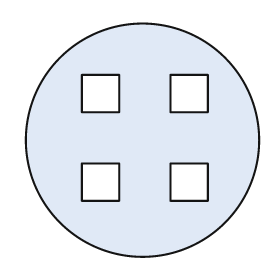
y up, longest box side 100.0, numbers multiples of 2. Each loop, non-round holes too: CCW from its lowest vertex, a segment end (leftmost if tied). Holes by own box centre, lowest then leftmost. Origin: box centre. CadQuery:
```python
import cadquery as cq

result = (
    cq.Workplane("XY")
    .moveTo(0.0, 0.0)
    .circle(50.0)
    .moveTo(-26.0, -26.0)
    .lineTo(-10.0, -26.0)
    .lineTo(-10.0, -10.0)
    .lineTo(-26.0, -10.0)
    .close()
    .moveTo(12.0, -26.0)
    .lineTo(28.0, -26.0)
    .lineTo(28.0, -10.0)
    .lineTo(12.0, -10.0)
    .close()
    .moveTo(-26.0, 12.0)
    .lineTo(-10.0, 12.0)
    .lineTo(-10.0, 28.0)
    .lineTo(-26.0, 28.0)
    .close()
    .moveTo(12.0, 12.0)
    .lineTo(28.0, 12.0)
    .lineTo(28.0, 28.0)
    .lineTo(12.0, 28.0)
    .close()
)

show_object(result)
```